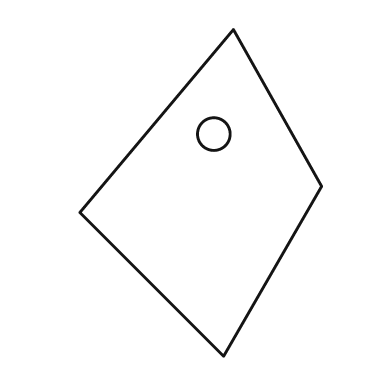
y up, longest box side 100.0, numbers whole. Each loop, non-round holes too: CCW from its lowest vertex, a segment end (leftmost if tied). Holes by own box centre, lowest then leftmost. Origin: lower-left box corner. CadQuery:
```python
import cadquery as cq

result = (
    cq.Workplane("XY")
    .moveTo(44.0, 0.0)
    .lineTo(74.0, 52.0)
    .lineTo(47.0, 100.0)
    .lineTo(0.0, 44.0)
    .close()
    .moveTo(41.0, 68.0)
    .circle(5.0)
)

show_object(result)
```